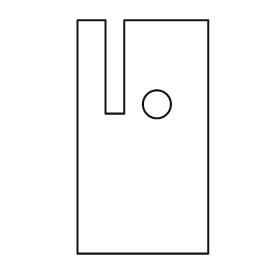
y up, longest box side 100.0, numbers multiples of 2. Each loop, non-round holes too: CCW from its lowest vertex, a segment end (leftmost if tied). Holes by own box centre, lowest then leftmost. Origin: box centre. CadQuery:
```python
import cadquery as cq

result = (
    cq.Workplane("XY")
    .moveTo(-28.0, -50.0)
    .lineTo(28.0, -50.0)
    .lineTo(28.0, 50.0)
    .lineTo(-8.0, 50.0)
    .lineTo(-8.0, 10.0)
    .lineTo(-16.0, 10.0)
    .lineTo(-16.0, 50.0)
    .lineTo(-28.0, 50.0)
    .close()
    .moveTo(6.0, 14.0)
    .circle(6.0)
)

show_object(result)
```